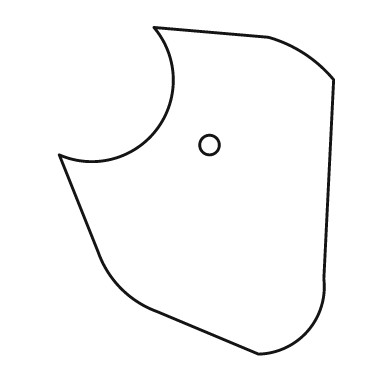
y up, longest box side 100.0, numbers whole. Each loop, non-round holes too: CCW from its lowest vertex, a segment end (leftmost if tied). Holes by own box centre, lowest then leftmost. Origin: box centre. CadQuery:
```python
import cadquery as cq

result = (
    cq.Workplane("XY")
    .moveTo(19.0, -50.0)
    .threePointArc((34.0, -43.0), (39.0, -27.0))
    .lineTo(42.0, 34.0)
    .threePointArc((33.0, 42.0), (22.0, 47.0))
    .lineTo(-13.0, 50.0)
    .threePointArc((-12.0, 19.0), (-42.0, 11.0))
    .lineTo(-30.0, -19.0)
    .threePointArc((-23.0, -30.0), (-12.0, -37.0))
    .close()
    .moveTo(4.0, 14.0)
    .circle(3.0)
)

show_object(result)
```